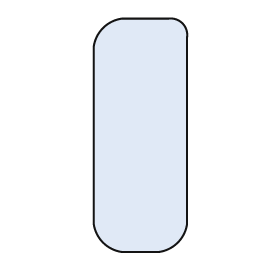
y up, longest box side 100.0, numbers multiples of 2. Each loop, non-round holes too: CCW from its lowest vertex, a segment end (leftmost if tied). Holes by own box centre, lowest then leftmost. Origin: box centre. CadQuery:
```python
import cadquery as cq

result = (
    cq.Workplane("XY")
    .moveTo(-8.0, -50.0)
    .lineTo(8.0, -50.0)
    .threePointArc((16.0, -46.0), (20.0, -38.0))
    .lineTo(20.0, 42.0)
    .threePointArc((18.0, 48.0), (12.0, 50.0))
    .lineTo(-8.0, 50.0)
    .threePointArc((-16.0, 46.0), (-20.0, 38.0))
    .lineTo(-20.0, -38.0)
    .threePointArc((-16.0, -46.0), (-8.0, -50.0))
    .close()
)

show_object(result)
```